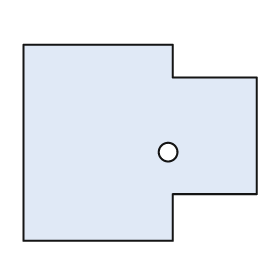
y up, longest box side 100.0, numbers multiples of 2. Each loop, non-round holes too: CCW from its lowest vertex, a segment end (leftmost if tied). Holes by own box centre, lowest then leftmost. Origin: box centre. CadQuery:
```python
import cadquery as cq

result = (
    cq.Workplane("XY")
    .moveTo(-50.0, -42.0)
    .lineTo(14.0, -42.0)
    .lineTo(14.0, -22.0)
    .lineTo(50.0, -22.0)
    .lineTo(50.0, 28.0)
    .lineTo(14.0, 28.0)
    .lineTo(14.0, 42.0)
    .lineTo(-50.0, 42.0)
    .close()
    .moveTo(12.0, -4.0)
    .circle(4.0)
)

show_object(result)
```